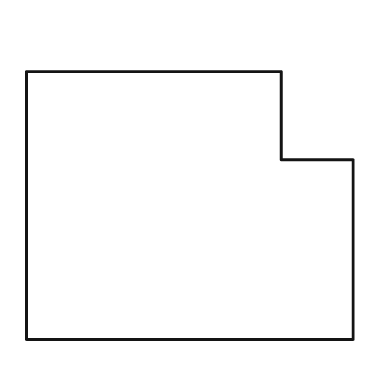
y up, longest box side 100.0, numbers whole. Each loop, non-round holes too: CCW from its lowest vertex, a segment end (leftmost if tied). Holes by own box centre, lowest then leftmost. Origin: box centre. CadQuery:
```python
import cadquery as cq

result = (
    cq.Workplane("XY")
    .moveTo(-50.0, -41.0)
    .lineTo(50.0, -41.0)
    .lineTo(50.0, 14.0)
    .lineTo(28.0, 14.0)
    .lineTo(28.0, 41.0)
    .lineTo(-50.0, 41.0)
    .close()
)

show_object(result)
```